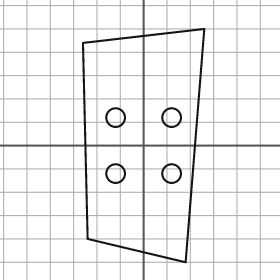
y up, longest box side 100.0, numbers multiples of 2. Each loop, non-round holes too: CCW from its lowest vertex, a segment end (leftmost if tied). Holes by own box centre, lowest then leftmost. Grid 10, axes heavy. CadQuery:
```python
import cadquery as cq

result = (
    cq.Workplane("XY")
    .moveTo(18.0, -50.0)
    .lineTo(26.0, 50.0)
    .lineTo(-26.0, 44.0)
    .lineTo(-24.0, -40.0)
    .close()
    .moveTo(-12.0, -12.0)
    .circle(4.0)
    .moveTo(12.0, -12.0)
    .circle(4.0)
    .moveTo(-12.0, 12.0)
    .circle(4.0)
    .moveTo(12.0, 12.0)
    .circle(4.0)
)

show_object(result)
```